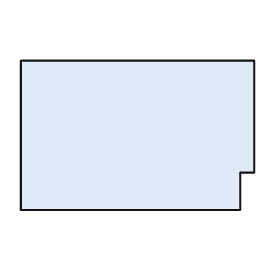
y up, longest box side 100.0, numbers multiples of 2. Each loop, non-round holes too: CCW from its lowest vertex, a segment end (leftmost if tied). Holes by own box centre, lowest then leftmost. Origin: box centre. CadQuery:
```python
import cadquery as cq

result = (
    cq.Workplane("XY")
    .moveTo(-50.0, -32.0)
    .lineTo(44.0, -32.0)
    .lineTo(44.0, -16.0)
    .lineTo(50.0, -16.0)
    .lineTo(50.0, 32.0)
    .lineTo(-50.0, 32.0)
    .close()
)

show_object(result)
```